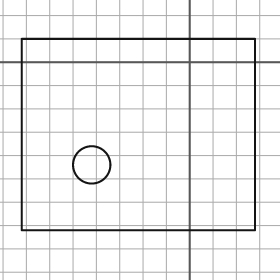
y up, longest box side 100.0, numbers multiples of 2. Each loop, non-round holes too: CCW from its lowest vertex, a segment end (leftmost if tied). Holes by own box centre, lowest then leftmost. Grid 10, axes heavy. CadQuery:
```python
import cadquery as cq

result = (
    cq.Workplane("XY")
    .moveTo(-72.0, -72.0)
    .lineTo(28.0, -72.0)
    .lineTo(28.0, 10.0)
    .lineTo(-72.0, 10.0)
    .close()
    .moveTo(-42.0, -44.0)
    .circle(8.0)
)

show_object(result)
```